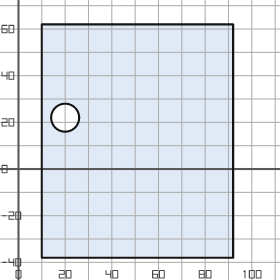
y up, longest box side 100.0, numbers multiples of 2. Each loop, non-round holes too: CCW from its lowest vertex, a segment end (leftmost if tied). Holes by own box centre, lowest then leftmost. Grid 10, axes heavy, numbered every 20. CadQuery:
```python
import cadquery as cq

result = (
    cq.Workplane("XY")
    .moveTo(10.0, -38.0)
    .lineTo(92.0, -38.0)
    .lineTo(92.0, 62.0)
    .lineTo(10.0, 62.0)
    .close()
    .moveTo(20.0, 22.0)
    .circle(6.0)
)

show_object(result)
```